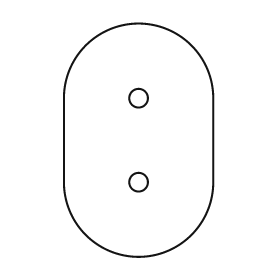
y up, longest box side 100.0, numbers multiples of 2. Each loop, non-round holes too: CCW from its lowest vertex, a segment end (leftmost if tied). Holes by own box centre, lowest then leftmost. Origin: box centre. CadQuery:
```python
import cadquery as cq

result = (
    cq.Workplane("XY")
    .moveTo(-32.0, -18.0)
    .threePointArc((0.0, -50.0), (32.0, -18.0))
    .lineTo(32.0, 18.0)
    .threePointArc((0.0, 50.0), (-32.0, 18.0))
    .close()
    .moveTo(0.0, -18.0)
    .circle(4.0)
    .moveTo(0.0, 18.0)
    .circle(4.0)
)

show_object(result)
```